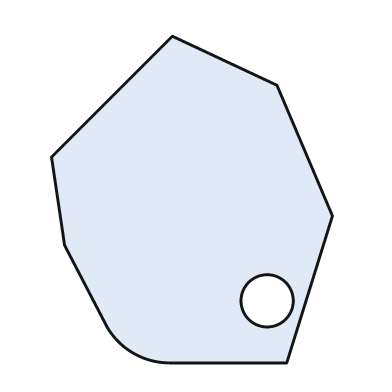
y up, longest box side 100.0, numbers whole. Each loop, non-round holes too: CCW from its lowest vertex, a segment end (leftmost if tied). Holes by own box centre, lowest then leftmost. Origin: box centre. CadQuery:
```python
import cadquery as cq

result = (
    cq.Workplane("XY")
    .moveTo(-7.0, -50.0)
    .lineTo(29.0, -50.0)
    .lineTo(43.0, -5.0)
    .lineTo(26.0, 35.0)
    .lineTo(-6.0, 50.0)
    .lineTo(-43.0, 13.0)
    .lineTo(-39.0, -14.0)
    .lineTo(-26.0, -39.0)
    .threePointArc((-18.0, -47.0), (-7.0, -50.0))
    .close()
    .moveTo(23.0, -31.0)
    .circle(8.0)
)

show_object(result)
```